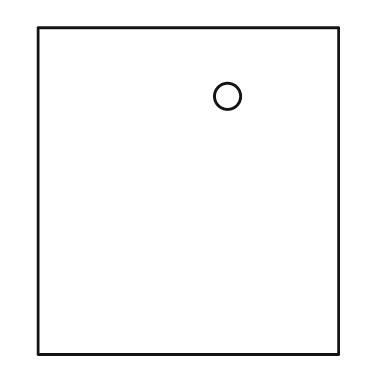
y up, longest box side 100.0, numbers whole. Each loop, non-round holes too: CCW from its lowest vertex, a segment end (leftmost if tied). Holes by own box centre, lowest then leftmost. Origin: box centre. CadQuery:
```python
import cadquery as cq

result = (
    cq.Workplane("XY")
    .moveTo(-46.0, -50.0)
    .lineTo(46.0, -50.0)
    .lineTo(46.0, 50.0)
    .lineTo(-46.0, 50.0)
    .close()
    .moveTo(12.0, 29.0)
    .circle(4.0)
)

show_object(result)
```